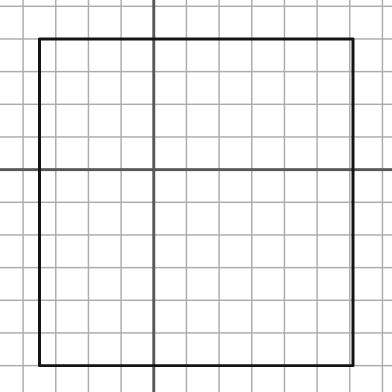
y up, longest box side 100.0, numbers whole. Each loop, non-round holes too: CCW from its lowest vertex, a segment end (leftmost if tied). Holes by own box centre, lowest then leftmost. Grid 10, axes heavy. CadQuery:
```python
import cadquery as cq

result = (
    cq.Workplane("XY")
    .moveTo(-35.0, -60.0)
    .lineTo(61.0, -60.0)
    .lineTo(61.0, 40.0)
    .lineTo(-35.0, 40.0)
    .close()
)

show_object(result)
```